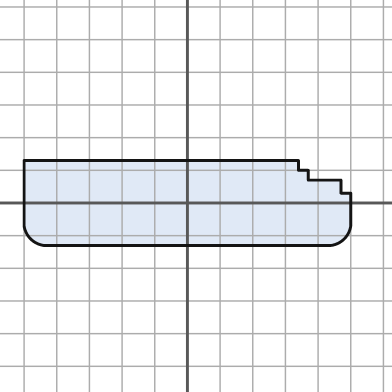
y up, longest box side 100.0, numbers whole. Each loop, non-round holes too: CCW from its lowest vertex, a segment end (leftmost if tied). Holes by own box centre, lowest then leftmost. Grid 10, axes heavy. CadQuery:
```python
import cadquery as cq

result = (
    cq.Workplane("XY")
    .moveTo(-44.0, -13.0)
    .lineTo(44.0, -13.0)
    .threePointArc((48.0, -11.0), (50.0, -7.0))
    .lineTo(50.0, 3.0)
    .lineTo(47.0, 3.0)
    .lineTo(47.0, 7.0)
    .lineTo(37.0, 7.0)
    .lineTo(37.0, 10.0)
    .lineTo(34.0, 10.0)
    .lineTo(34.0, 13.0)
    .lineTo(-50.0, 13.0)
    .lineTo(-50.0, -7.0)
    .threePointArc((-48.0, -11.0), (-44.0, -13.0))
    .close()
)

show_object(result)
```